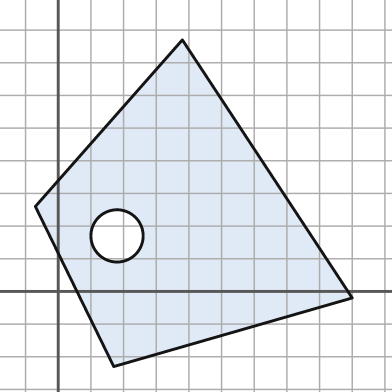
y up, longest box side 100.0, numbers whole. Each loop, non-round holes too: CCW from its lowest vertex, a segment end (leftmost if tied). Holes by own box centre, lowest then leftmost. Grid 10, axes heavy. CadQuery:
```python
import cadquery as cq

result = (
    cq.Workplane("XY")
    .moveTo(17.0, -23.0)
    .lineTo(90.0, -2.0)
    .lineTo(38.0, 77.0)
    .lineTo(-7.0, 26.0)
    .close()
    .moveTo(18.0, 17.0)
    .circle(8.0)
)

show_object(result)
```